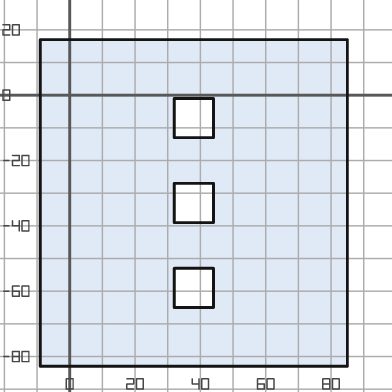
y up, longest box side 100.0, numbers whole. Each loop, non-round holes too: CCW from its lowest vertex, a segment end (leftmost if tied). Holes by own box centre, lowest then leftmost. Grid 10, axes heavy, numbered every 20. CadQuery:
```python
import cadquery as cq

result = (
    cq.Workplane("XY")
    .moveTo(-9.0, -83.0)
    .lineTo(85.0, -83.0)
    .lineTo(85.0, 17.0)
    .lineTo(-9.0, 17.0)
    .close()
    .moveTo(32.0, -65.0)
    .lineTo(44.0, -65.0)
    .lineTo(44.0, -53.0)
    .lineTo(32.0, -53.0)
    .close()
    .moveTo(32.0, -39.0)
    .lineTo(44.0, -39.0)
    .lineTo(44.0, -27.0)
    .lineTo(32.0, -27.0)
    .close()
    .moveTo(32.0, -13.0)
    .lineTo(44.0, -13.0)
    .lineTo(44.0, -1.0)
    .lineTo(32.0, -1.0)
    .close()
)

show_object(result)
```